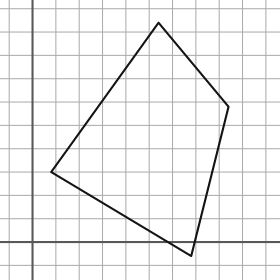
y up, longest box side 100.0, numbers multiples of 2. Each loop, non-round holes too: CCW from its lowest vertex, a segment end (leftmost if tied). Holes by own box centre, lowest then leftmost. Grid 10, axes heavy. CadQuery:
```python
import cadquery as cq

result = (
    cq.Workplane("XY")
    .moveTo(68.0, -6.0)
    .lineTo(84.0, 58.0)
    .lineTo(54.0, 94.0)
    .lineTo(8.0, 30.0)
    .close()
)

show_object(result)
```